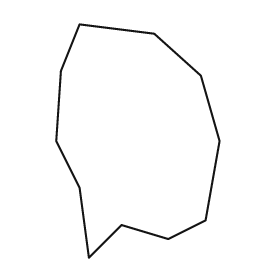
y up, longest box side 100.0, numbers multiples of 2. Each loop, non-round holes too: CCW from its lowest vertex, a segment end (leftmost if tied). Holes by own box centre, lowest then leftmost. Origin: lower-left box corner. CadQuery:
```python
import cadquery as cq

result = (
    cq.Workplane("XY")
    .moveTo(14.0, 0.0)
    .lineTo(28.0, 14.0)
    .lineTo(48.0, 8.0)
    .lineTo(64.0, 16.0)
    .lineTo(70.0, 50.0)
    .lineTo(62.0, 78.0)
    .lineTo(42.0, 96.0)
    .lineTo(10.0, 100.0)
    .lineTo(2.0, 80.0)
    .lineTo(0.0, 50.0)
    .lineTo(10.0, 30.0)
    .close()
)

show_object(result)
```